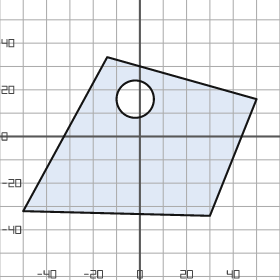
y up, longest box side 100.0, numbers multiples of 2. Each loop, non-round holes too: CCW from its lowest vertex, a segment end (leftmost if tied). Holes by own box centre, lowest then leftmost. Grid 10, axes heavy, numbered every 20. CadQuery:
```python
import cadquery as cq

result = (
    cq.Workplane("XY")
    .moveTo(30.0, -34.0)
    .lineTo(50.0, 16.0)
    .lineTo(-14.0, 34.0)
    .lineTo(-50.0, -32.0)
    .close()
    .moveTo(-2.0, 16.0)
    .circle(8.0)
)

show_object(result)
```